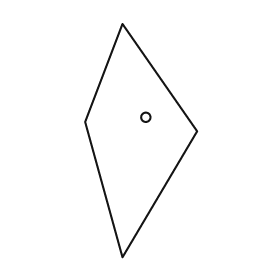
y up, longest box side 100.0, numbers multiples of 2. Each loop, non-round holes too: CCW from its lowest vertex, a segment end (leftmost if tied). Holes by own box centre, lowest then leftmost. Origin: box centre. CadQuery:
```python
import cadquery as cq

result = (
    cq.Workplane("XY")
    .moveTo(-8.0, -50.0)
    .lineTo(24.0, 4.0)
    .lineTo(-8.0, 50.0)
    .lineTo(-24.0, 8.0)
    .close()
    .moveTo(2.0, 10.0)
    .circle(2.0)
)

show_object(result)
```